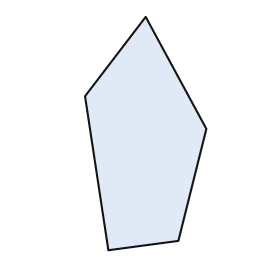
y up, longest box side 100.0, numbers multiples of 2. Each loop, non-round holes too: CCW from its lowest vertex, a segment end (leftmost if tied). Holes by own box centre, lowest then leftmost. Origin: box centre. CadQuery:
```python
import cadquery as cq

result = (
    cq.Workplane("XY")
    .moveTo(-16.0, -50.0)
    .lineTo(14.0, -46.0)
    .lineTo(26.0, 2.0)
    .lineTo(0.0, 50.0)
    .lineTo(-26.0, 16.0)
    .close()
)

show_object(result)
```